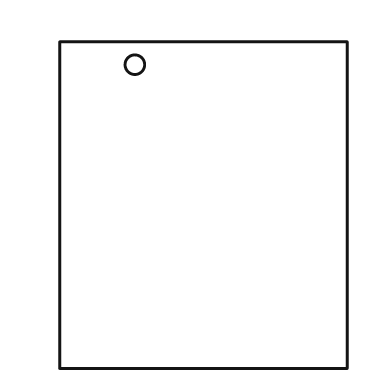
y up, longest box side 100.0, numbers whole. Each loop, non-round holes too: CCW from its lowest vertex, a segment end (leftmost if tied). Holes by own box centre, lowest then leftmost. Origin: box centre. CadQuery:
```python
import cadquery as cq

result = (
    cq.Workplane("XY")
    .moveTo(-44.0, -50.0)
    .lineTo(44.0, -50.0)
    .lineTo(44.0, 50.0)
    .lineTo(-44.0, 50.0)
    .close()
    .moveTo(-21.0, 43.0)
    .circle(3.0)
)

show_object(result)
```